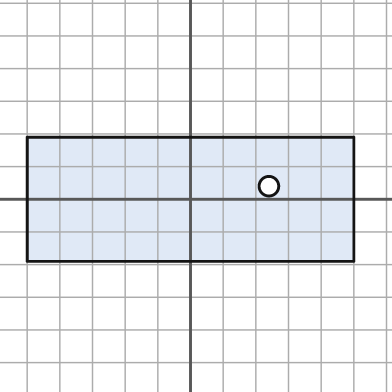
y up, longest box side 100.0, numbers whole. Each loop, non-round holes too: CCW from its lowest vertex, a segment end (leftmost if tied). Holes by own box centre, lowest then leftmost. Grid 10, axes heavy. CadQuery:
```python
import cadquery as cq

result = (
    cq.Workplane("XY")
    .moveTo(-50.0, -19.0)
    .lineTo(50.0, -19.0)
    .lineTo(50.0, 19.0)
    .lineTo(-50.0, 19.0)
    .close()
    .moveTo(24.0, 4.0)
    .circle(3.0)
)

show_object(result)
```